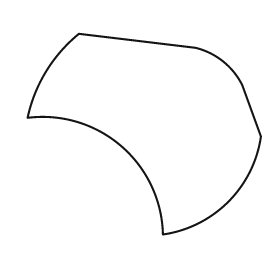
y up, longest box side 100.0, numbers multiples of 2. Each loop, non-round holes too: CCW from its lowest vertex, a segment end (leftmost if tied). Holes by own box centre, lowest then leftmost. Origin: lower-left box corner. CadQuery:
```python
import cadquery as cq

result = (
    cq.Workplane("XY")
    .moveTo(58.0, 0.0)
    .threePointArc((86.0, 14.0), (100.0, 42.0))
    .lineTo(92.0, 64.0)
    .threePointArc((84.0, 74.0), (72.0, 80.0))
    .lineTo(22.0, 86.0)
    .threePointArc((8.0, 70.0), (0.0, 50.0))
    .threePointArc((40.0, 38.0), (58.0, 0.0))
    .close()
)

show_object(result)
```